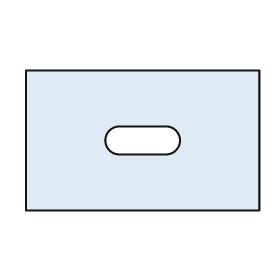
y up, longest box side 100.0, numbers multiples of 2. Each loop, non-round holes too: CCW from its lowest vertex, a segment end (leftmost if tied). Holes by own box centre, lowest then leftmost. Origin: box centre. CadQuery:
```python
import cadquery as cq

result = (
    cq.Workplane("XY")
    .moveTo(-50.0, -30.0)
    .lineTo(50.0, -30.0)
    .lineTo(50.0, 30.0)
    .lineTo(-50.0, 30.0)
    .close()
    .moveTo(-10.0, -6.0)
    .lineTo(10.0, -6.0)
    .threePointArc((16.0, 0.0), (10.0, 6.0))
    .lineTo(-10.0, 6.0)
    .threePointArc((-16.0, 0.0), (-10.0, -6.0))
    .close()
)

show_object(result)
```